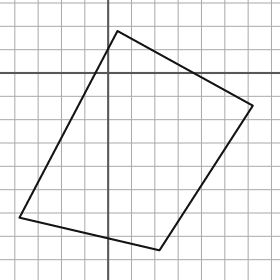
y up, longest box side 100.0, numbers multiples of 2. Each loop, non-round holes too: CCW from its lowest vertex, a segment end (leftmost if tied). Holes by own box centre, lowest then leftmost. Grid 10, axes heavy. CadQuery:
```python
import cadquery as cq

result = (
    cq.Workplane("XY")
    .moveTo(22.0, -76.0)
    .lineTo(62.0, -14.0)
    .lineTo(4.0, 18.0)
    .lineTo(-38.0, -62.0)
    .close()
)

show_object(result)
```